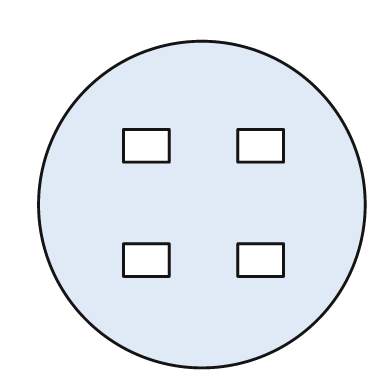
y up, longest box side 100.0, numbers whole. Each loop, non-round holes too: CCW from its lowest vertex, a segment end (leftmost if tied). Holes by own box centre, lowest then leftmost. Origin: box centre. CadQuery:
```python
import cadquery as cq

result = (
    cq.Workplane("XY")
    .moveTo(0.0, 0.0)
    .circle(50.0)
    .moveTo(-24.0, -22.0)
    .lineTo(-10.0, -22.0)
    .lineTo(-10.0, -12.0)
    .lineTo(-24.0, -12.0)
    .close()
    .moveTo(11.0, -22.0)
    .lineTo(25.0, -22.0)
    .lineTo(25.0, -12.0)
    .lineTo(11.0, -12.0)
    .close()
    .moveTo(-24.0, 13.0)
    .lineTo(-10.0, 13.0)
    .lineTo(-10.0, 23.0)
    .lineTo(-24.0, 23.0)
    .close()
    .moveTo(11.0, 13.0)
    .lineTo(25.0, 13.0)
    .lineTo(25.0, 23.0)
    .lineTo(11.0, 23.0)
    .close()
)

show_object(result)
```